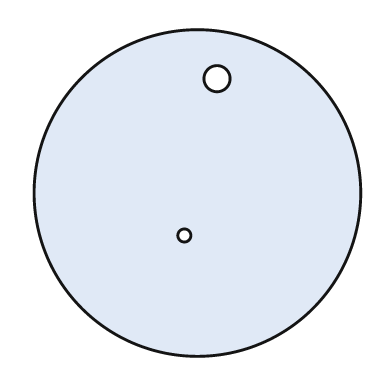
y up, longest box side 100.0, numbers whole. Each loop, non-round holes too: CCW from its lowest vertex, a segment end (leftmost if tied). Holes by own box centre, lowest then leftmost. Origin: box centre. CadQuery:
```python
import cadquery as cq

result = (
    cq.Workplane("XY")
    .moveTo(0.0, 0.0)
    .circle(50.0)
    .moveTo(-4.0, -13.0)
    .circle(2.0)
    .moveTo(6.0, 35.0)
    .circle(4.0)
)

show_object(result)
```